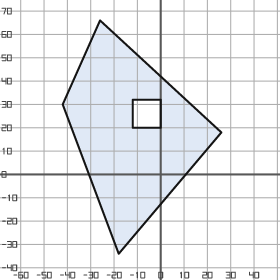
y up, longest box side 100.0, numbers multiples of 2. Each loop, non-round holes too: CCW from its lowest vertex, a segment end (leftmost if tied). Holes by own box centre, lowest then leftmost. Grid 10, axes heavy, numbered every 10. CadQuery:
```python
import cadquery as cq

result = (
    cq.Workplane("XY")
    .moveTo(-18.0, -34.0)
    .lineTo(26.0, 18.0)
    .lineTo(-26.0, 66.0)
    .lineTo(-42.0, 30.0)
    .close()
    .moveTo(-12.0, 20.0)
    .lineTo(0.0, 20.0)
    .lineTo(0.0, 32.0)
    .lineTo(-12.0, 32.0)
    .close()
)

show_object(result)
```